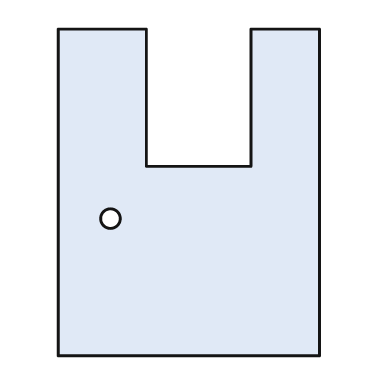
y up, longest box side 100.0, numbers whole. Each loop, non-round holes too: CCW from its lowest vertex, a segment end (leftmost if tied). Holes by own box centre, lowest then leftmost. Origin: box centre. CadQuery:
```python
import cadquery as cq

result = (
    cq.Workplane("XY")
    .moveTo(-40.0, -50.0)
    .lineTo(40.0, -50.0)
    .lineTo(40.0, 50.0)
    .lineTo(19.0, 50.0)
    .lineTo(19.0, 8.0)
    .lineTo(-13.0, 8.0)
    .lineTo(-13.0, 50.0)
    .lineTo(-40.0, 50.0)
    .close()
    .moveTo(-24.0, -8.0)
    .circle(3.0)
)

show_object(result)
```